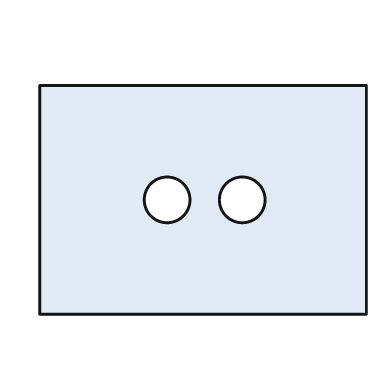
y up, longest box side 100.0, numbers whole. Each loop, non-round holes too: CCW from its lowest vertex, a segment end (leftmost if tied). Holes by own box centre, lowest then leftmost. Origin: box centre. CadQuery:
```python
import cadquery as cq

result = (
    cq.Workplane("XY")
    .moveTo(-50.0, -35.0)
    .lineTo(50.0, -35.0)
    .lineTo(50.0, 35.0)
    .lineTo(-50.0, 35.0)
    .close()
    .moveTo(-11.0, 0.0)
    .circle(7.0)
    .moveTo(12.0, 0.0)
    .circle(7.0)
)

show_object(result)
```